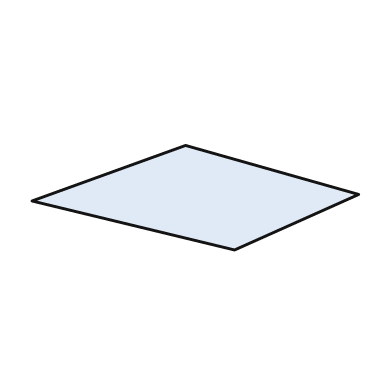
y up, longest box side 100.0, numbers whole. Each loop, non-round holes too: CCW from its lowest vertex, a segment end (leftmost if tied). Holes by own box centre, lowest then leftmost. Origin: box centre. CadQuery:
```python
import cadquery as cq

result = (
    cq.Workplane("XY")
    .moveTo(12.0, -16.0)
    .lineTo(50.0, 1.0)
    .lineTo(-3.0, 16.0)
    .lineTo(-50.0, -1.0)
    .close()
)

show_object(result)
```